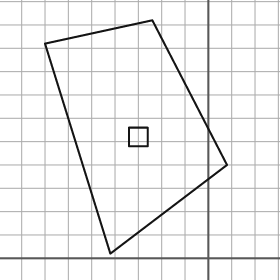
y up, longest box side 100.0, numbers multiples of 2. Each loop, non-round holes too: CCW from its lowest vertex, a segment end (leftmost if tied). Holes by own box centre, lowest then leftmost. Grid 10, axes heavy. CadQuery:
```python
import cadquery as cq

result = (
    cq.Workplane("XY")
    .moveTo(-42.0, 2.0)
    .lineTo(8.0, 40.0)
    .lineTo(-24.0, 102.0)
    .lineTo(-70.0, 92.0)
    .close()
    .moveTo(-34.0, 48.0)
    .lineTo(-26.0, 48.0)
    .lineTo(-26.0, 56.0)
    .lineTo(-34.0, 56.0)
    .close()
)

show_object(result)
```